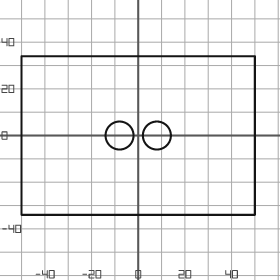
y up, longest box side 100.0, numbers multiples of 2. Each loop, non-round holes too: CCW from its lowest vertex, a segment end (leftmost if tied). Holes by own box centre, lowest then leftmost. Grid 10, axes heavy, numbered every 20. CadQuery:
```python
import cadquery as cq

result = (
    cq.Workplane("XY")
    .moveTo(-50.0, -34.0)
    .lineTo(50.0, -34.0)
    .lineTo(50.0, 34.0)
    .lineTo(-50.0, 34.0)
    .close()
    .moveTo(-8.0, 0.0)
    .circle(6.0)
    .moveTo(8.0, 0.0)
    .circle(6.0)
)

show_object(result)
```